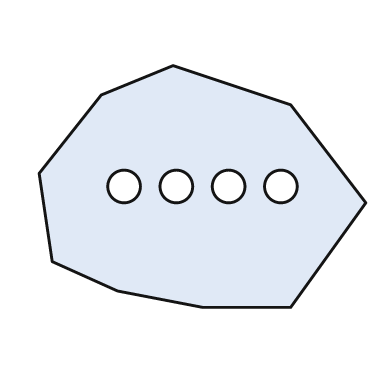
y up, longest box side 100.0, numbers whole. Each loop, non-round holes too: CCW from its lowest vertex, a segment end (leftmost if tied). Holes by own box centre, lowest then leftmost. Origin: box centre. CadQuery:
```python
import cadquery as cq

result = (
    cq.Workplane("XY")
    .moveTo(0.0, -37.0)
    .lineTo(27.0, -37.0)
    .lineTo(50.0, -5.0)
    .lineTo(27.0, 25.0)
    .lineTo(-9.0, 37.0)
    .lineTo(-31.0, 28.0)
    .lineTo(-50.0, 4.0)
    .lineTo(-46.0, -23.0)
    .lineTo(-26.0, -32.0)
    .close()
    .moveTo(-24.0, 0.0)
    .circle(5.0)
    .moveTo(-8.0, 0.0)
    .circle(5.0)
    .moveTo(8.0, 0.0)
    .circle(5.0)
    .moveTo(24.0, 0.0)
    .circle(5.0)
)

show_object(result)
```